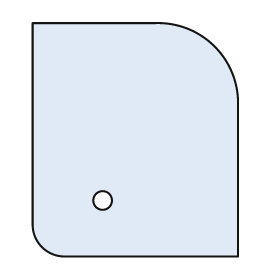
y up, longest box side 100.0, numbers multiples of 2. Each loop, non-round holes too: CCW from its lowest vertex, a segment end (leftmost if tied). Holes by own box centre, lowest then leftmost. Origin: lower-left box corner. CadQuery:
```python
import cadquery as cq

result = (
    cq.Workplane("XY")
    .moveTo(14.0, 0.0)
    .lineTo(88.0, 0.0)
    .lineTo(88.0, 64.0)
    .threePointArc((78.0, 90.0), (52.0, 100.0))
    .lineTo(0.0, 100.0)
    .lineTo(0.0, 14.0)
    .threePointArc((4.0, 4.0), (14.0, 0.0))
    .close()
    .moveTo(30.0, 24.0)
    .circle(4.0)
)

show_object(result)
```